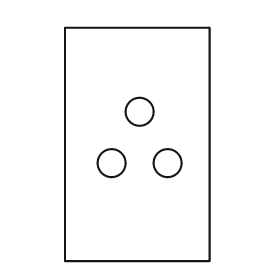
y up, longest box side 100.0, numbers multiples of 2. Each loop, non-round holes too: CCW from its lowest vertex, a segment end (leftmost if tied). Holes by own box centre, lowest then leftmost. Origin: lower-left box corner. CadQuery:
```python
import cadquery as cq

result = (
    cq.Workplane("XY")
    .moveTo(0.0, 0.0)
    .lineTo(62.0, 0.0)
    .lineTo(62.0, 100.0)
    .lineTo(0.0, 100.0)
    .close()
    .moveTo(20.0, 42.0)
    .circle(6.0)
    .moveTo(44.0, 42.0)
    .circle(6.0)
    .moveTo(32.0, 64.0)
    .circle(6.0)
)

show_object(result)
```